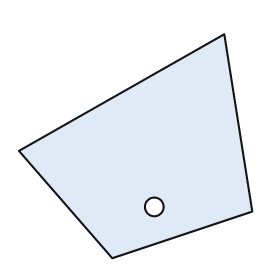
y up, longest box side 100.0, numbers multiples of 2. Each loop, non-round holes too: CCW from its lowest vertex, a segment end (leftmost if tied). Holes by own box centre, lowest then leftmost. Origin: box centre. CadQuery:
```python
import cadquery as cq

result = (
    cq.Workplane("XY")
    .moveTo(-10.0, -48.0)
    .lineTo(50.0, -28.0)
    .lineTo(38.0, 48.0)
    .lineTo(-50.0, -2.0)
    .close()
    .moveTo(8.0, -26.0)
    .circle(4.0)
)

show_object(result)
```